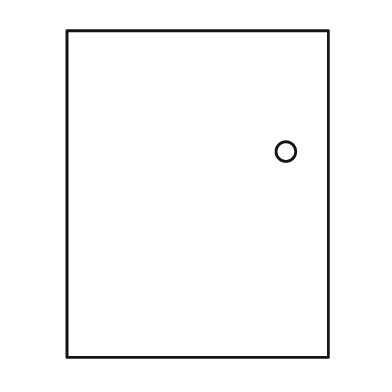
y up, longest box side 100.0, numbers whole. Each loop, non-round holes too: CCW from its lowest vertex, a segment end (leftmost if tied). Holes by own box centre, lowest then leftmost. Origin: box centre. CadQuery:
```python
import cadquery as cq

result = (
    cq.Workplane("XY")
    .moveTo(-40.0, -50.0)
    .lineTo(40.0, -50.0)
    .lineTo(40.0, 50.0)
    .lineTo(-40.0, 50.0)
    .close()
    .moveTo(27.0, 13.0)
    .circle(3.0)
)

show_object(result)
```